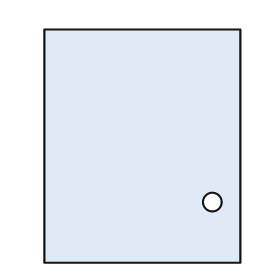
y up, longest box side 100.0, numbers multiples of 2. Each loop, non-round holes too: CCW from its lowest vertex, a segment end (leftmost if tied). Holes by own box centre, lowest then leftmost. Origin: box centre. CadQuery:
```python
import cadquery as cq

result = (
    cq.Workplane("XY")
    .moveTo(-42.0, -50.0)
    .lineTo(42.0, -50.0)
    .lineTo(42.0, 50.0)
    .lineTo(-42.0, 50.0)
    .close()
    .moveTo(30.0, -24.0)
    .circle(4.0)
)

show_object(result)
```